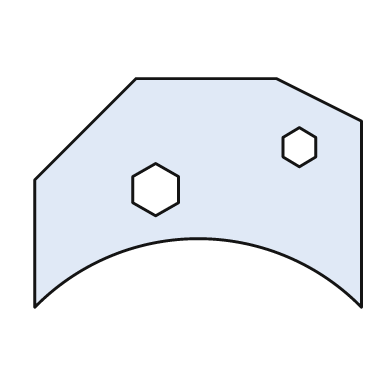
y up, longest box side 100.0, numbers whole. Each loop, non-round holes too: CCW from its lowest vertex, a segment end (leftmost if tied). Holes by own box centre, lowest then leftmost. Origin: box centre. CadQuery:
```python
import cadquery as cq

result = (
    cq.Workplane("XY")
    .moveTo(-50.0, -35.0)
    .threePointArc((0.0, -14.0), (50.0, -35.0))
    .lineTo(50.0, 22.0)
    .lineTo(24.0, 35.0)
    .lineTo(-19.0, 35.0)
    .lineTo(-50.0, 4.0)
    .close()
    .moveTo(-13.0, -7.0)
    .lineTo(-6.0, -3.0)
    .lineTo(-6.0, 5.0)
    .lineTo(-13.0, 9.0)
    .lineTo(-20.0, 5.0)
    .lineTo(-20.0, -3.0)
    .close()
    .moveTo(31.0, 8.0)
    .lineTo(36.0, 11.0)
    .lineTo(36.0, 17.0)
    .lineTo(31.0, 20.0)
    .lineTo(26.0, 17.0)
    .lineTo(26.0, 11.0)
    .close()
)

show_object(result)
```